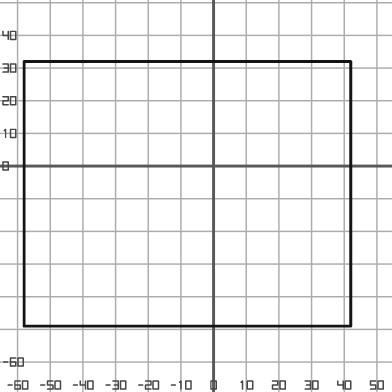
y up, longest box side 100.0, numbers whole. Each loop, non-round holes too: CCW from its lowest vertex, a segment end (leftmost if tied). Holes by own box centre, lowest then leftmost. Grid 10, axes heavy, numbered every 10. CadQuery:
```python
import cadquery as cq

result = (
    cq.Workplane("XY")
    .moveTo(-58.0, -49.0)
    .lineTo(42.0, -49.0)
    .lineTo(42.0, 32.0)
    .lineTo(-58.0, 32.0)
    .close()
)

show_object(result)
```